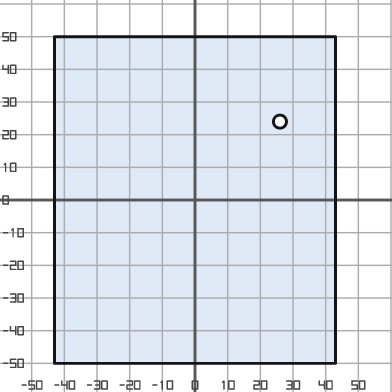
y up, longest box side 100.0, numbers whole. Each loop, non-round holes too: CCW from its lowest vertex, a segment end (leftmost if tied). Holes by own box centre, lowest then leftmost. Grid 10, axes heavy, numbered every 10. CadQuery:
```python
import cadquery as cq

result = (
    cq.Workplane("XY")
    .moveTo(-43.0, -50.0)
    .lineTo(43.0, -50.0)
    .lineTo(43.0, 50.0)
    .lineTo(-43.0, 50.0)
    .close()
    .moveTo(26.0, 24.0)
    .circle(2.0)
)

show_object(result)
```